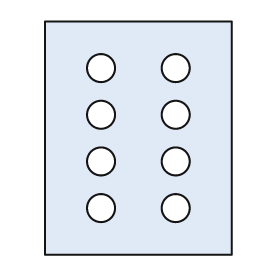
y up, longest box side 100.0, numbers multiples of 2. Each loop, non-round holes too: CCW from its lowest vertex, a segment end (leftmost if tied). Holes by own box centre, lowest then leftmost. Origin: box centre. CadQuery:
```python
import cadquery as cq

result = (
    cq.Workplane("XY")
    .moveTo(-40.0, -50.0)
    .lineTo(40.0, -50.0)
    .lineTo(40.0, 50.0)
    .lineTo(-40.0, 50.0)
    .close()
    .moveTo(-16.0, -30.0)
    .circle(6.0)
    .moveTo(16.0, -30.0)
    .circle(6.0)
    .moveTo(-16.0, -10.0)
    .circle(6.0)
    .moveTo(16.0, -10.0)
    .circle(6.0)
    .moveTo(-16.0, 10.0)
    .circle(6.0)
    .moveTo(16.0, 10.0)
    .circle(6.0)
    .moveTo(-16.0, 30.0)
    .circle(6.0)
    .moveTo(16.0, 30.0)
    .circle(6.0)
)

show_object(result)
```